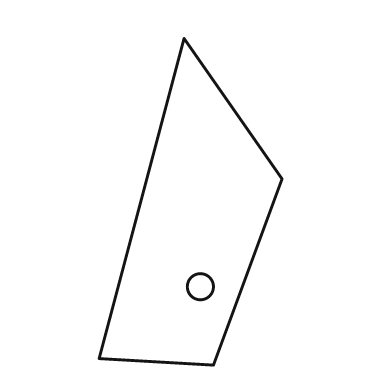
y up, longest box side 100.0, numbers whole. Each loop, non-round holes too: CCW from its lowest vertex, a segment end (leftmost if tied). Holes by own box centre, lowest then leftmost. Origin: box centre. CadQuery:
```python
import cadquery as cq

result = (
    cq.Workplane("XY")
    .moveTo(7.0, -50.0)
    .lineTo(28.0, 7.0)
    .lineTo(-2.0, 50.0)
    .lineTo(-28.0, -48.0)
    .close()
    .moveTo(3.0, -26.0)
    .circle(4.0)
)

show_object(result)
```